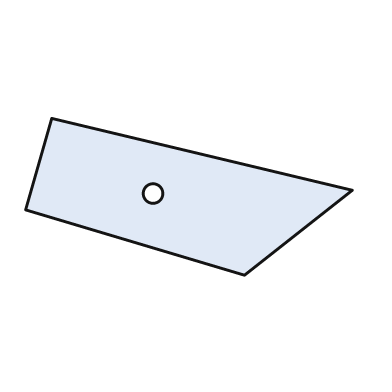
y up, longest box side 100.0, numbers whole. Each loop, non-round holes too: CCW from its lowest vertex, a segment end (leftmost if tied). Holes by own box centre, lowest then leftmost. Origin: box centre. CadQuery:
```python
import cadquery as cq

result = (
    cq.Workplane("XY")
    .moveTo(17.0, -24.0)
    .lineTo(50.0, 2.0)
    .lineTo(-42.0, 24.0)
    .lineTo(-50.0, -4.0)
    .close()
    .moveTo(-11.0, 1.0)
    .circle(3.0)
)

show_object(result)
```